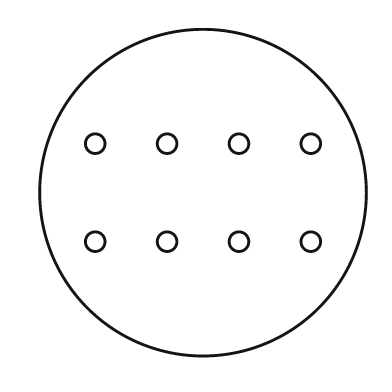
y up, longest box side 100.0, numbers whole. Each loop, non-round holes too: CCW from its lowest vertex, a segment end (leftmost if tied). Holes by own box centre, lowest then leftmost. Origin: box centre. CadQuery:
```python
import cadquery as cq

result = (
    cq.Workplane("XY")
    .moveTo(0.0, 0.0)
    .circle(50.0)
    .moveTo(-33.0, -15.0)
    .circle(3.0)
    .moveTo(-11.0, -15.0)
    .circle(3.0)
    .moveTo(11.0, -15.0)
    .circle(3.0)
    .moveTo(33.0, -15.0)
    .circle(3.0)
    .moveTo(-33.0, 15.0)
    .circle(3.0)
    .moveTo(-11.0, 15.0)
    .circle(3.0)
    .moveTo(11.0, 15.0)
    .circle(3.0)
    .moveTo(33.0, 15.0)
    .circle(3.0)
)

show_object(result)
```